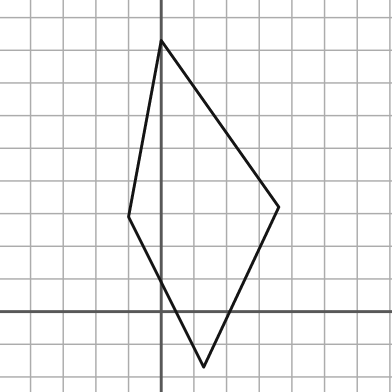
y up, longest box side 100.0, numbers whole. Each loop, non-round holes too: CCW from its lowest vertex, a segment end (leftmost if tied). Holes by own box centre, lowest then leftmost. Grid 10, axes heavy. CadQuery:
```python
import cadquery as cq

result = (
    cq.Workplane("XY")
    .moveTo(13.0, -17.0)
    .lineTo(36.0, 32.0)
    .lineTo(0.0, 83.0)
    .lineTo(-10.0, 29.0)
    .close()
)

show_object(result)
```